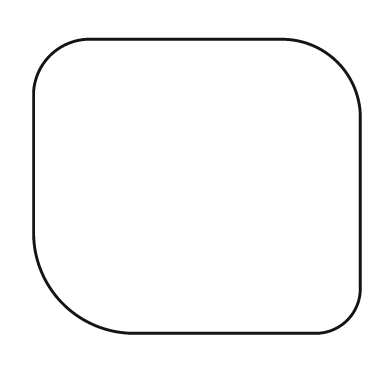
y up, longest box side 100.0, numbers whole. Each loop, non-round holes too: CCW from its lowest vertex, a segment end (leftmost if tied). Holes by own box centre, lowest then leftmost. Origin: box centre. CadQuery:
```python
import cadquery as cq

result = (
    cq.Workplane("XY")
    .moveTo(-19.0, -45.0)
    .lineTo(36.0, -45.0)
    .threePointArc((46.0, -41.0), (50.0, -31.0))
    .lineTo(50.0, 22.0)
    .threePointArc((43.0, 38.0), (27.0, 45.0))
    .lineTo(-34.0, 45.0)
    .threePointArc((-45.0, 40.0), (-50.0, 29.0))
    .lineTo(-50.0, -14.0)
    .threePointArc((-41.0, -36.0), (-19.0, -45.0))
    .close()
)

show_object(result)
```